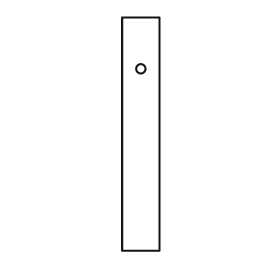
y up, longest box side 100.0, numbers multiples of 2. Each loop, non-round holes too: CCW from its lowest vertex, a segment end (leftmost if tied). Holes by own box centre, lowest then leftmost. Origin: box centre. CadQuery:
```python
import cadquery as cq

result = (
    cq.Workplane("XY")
    .moveTo(-8.0, -50.0)
    .lineTo(8.0, -50.0)
    .lineTo(8.0, 50.0)
    .lineTo(-8.0, 50.0)
    .close()
    .moveTo(0.0, 28.0)
    .circle(2.0)
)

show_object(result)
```